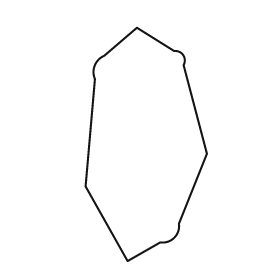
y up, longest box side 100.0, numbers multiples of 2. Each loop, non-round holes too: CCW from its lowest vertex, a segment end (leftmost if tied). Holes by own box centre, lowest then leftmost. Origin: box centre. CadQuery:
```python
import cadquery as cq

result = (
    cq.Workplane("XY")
    .moveTo(-8.0, -50.0)
    .lineTo(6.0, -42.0)
    .threePointArc((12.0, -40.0), (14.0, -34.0))
    .lineTo(26.0, -4.0)
    .lineTo(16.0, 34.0)
    .threePointArc((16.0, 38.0), (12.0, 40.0))
    .lineTo(-4.0, 50.0)
    .lineTo(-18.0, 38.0)
    .threePointArc((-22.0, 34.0), (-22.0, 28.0))
    .lineTo(-26.0, -18.0)
    .close()
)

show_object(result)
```